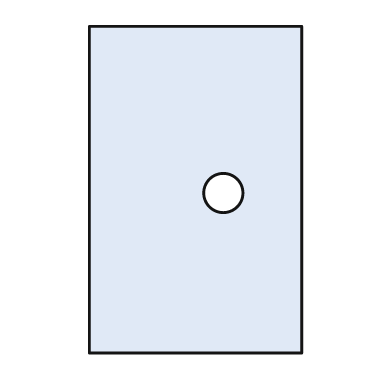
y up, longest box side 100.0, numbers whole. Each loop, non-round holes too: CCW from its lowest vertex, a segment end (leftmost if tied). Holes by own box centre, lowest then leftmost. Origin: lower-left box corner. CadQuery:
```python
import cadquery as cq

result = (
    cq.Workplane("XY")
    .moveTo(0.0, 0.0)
    .lineTo(65.0, 0.0)
    .lineTo(65.0, 100.0)
    .lineTo(0.0, 100.0)
    .close()
    .moveTo(41.0, 49.0)
    .circle(6.0)
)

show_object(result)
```